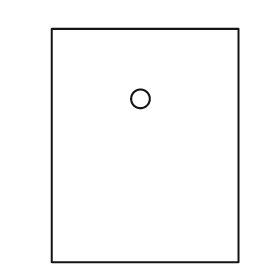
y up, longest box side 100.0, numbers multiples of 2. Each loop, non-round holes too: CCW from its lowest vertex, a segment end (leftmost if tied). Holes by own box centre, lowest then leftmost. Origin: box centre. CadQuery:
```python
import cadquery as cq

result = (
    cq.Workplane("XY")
    .moveTo(-40.0, -50.0)
    .lineTo(40.0, -50.0)
    .lineTo(40.0, 50.0)
    .lineTo(-40.0, 50.0)
    .close()
    .moveTo(-2.0, 20.0)
    .circle(4.0)
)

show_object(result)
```